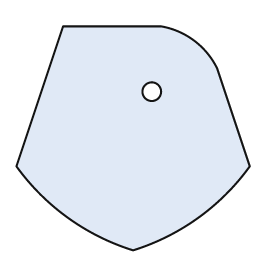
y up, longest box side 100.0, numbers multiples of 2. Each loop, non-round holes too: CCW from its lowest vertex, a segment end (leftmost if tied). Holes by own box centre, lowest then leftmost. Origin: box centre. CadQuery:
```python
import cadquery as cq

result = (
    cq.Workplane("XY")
    .moveTo(0.0, -48.0)
    .threePointArc((28.0, -34.0), (50.0, -12.0))
    .lineTo(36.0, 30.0)
    .threePointArc((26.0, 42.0), (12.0, 48.0))
    .lineTo(-30.0, 48.0)
    .lineTo(-50.0, -12.0)
    .threePointArc((-28.0, -34.0), (0.0, -48.0))
    .close()
    .moveTo(8.0, 20.0)
    .circle(4.0)
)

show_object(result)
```